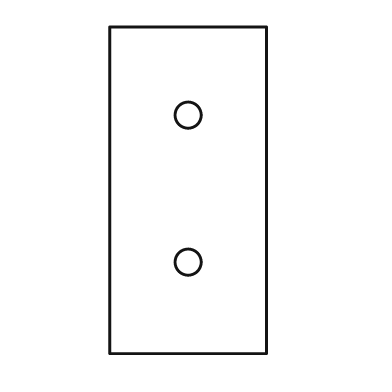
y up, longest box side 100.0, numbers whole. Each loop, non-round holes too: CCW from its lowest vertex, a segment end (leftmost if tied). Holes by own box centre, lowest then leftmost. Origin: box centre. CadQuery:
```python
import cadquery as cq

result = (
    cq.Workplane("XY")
    .moveTo(-24.0, -50.0)
    .lineTo(24.0, -50.0)
    .lineTo(24.0, 50.0)
    .lineTo(-24.0, 50.0)
    .close()
    .moveTo(0.0, -22.0)
    .circle(4.0)
    .moveTo(0.0, 23.0)
    .circle(4.0)
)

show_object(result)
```